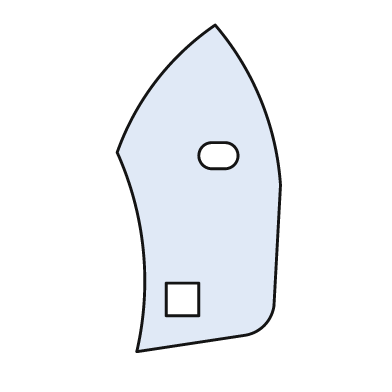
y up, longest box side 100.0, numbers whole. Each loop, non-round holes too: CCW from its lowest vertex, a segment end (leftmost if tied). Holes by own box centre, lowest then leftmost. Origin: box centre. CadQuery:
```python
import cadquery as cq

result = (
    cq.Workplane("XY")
    .moveTo(-19.0, -50.0)
    .lineTo(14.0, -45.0)
    .threePointArc((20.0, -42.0), (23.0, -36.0))
    .lineTo(25.0, 1.0)
    .threePointArc((19.0, 27.0), (5.0, 50.0))
    .threePointArc((-13.0, 33.0), (-25.0, 11.0))
    .threePointArc((-17.0, -19.0), (-19.0, -50.0))
    .close()
    .moveTo(-10.0, -39.0)
    .lineTo(0.0, -39.0)
    .lineTo(0.0, -29.0)
    .lineTo(-10.0, -29.0)
    .close()
    .moveTo(4.0, 6.0)
    .lineTo(8.0, 6.0)
    .threePointArc((12.0, 10.0), (8.0, 14.0))
    .lineTo(4.0, 14.0)
    .threePointArc((0.0, 10.0), (4.0, 6.0))
    .close()
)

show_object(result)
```